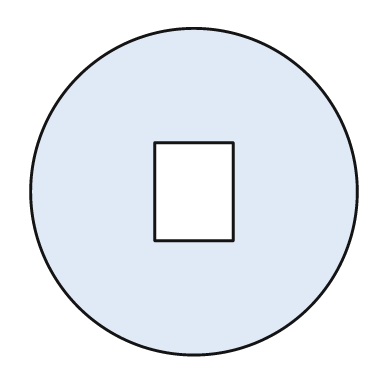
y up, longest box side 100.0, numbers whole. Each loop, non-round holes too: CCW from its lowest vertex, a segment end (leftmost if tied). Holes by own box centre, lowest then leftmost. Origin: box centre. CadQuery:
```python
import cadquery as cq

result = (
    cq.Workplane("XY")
    .moveTo(0.0, 0.0)
    .circle(50.0)
    .moveTo(-12.0, -15.0)
    .lineTo(12.0, -15.0)
    .lineTo(12.0, 15.0)
    .lineTo(-12.0, 15.0)
    .close()
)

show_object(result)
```